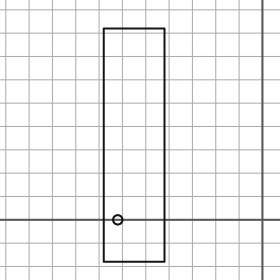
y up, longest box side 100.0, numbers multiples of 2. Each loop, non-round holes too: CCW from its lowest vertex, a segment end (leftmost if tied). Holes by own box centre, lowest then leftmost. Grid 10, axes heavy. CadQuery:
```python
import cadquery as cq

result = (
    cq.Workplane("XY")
    .moveTo(-68.0, -18.0)
    .lineTo(-42.0, -18.0)
    .lineTo(-42.0, 82.0)
    .lineTo(-68.0, 82.0)
    .close()
    .moveTo(-62.0, 0.0)
    .circle(2.0)
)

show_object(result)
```